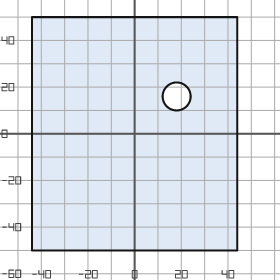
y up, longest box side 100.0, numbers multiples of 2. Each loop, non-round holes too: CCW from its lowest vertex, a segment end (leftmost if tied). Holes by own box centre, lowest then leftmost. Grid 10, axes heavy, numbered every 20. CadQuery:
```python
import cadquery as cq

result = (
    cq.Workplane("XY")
    .moveTo(-44.0, -50.0)
    .lineTo(44.0, -50.0)
    .lineTo(44.0, 50.0)
    .lineTo(-44.0, 50.0)
    .close()
    .moveTo(18.0, 16.0)
    .circle(6.0)
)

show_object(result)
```